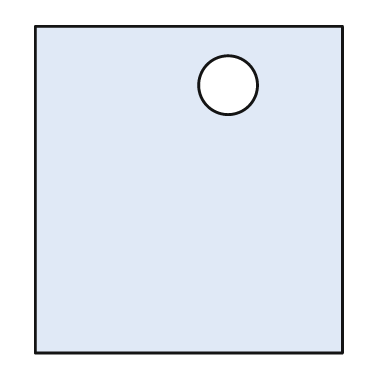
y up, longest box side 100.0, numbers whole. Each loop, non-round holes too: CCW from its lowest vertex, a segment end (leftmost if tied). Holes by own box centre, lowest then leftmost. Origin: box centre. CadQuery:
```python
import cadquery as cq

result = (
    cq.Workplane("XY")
    .moveTo(-47.0, -50.0)
    .lineTo(47.0, -50.0)
    .lineTo(47.0, 50.0)
    .lineTo(-47.0, 50.0)
    .close()
    .moveTo(12.0, 32.0)
    .circle(9.0)
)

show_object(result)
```